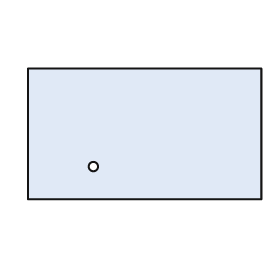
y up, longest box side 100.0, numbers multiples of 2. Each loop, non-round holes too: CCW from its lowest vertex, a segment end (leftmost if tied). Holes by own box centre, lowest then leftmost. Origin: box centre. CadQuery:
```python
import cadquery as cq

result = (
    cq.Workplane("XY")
    .moveTo(-50.0, -28.0)
    .lineTo(50.0, -28.0)
    .lineTo(50.0, 28.0)
    .lineTo(-50.0, 28.0)
    .close()
    .moveTo(-22.0, -14.0)
    .circle(2.0)
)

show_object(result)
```